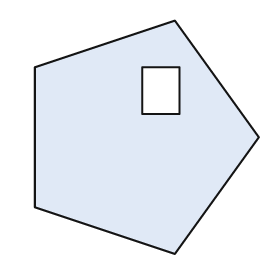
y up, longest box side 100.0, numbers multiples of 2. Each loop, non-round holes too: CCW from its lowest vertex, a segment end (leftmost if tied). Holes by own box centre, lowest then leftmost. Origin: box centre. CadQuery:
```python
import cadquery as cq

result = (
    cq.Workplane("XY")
    .moveTo(12.0, -50.0)
    .lineTo(48.0, 0.0)
    .lineTo(12.0, 50.0)
    .lineTo(-48.0, 30.0)
    .lineTo(-48.0, -30.0)
    .close()
    .moveTo(-2.0, 10.0)
    .lineTo(14.0, 10.0)
    .lineTo(14.0, 30.0)
    .lineTo(-2.0, 30.0)
    .close()
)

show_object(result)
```